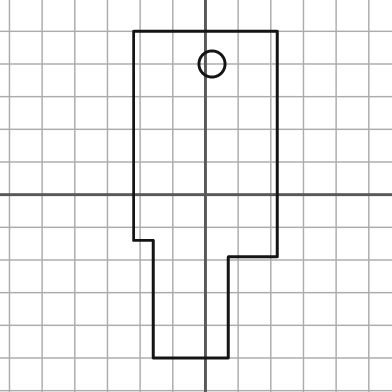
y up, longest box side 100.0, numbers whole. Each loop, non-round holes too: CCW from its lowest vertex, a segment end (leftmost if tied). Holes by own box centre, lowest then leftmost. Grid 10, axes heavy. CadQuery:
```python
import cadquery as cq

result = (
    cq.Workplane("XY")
    .moveTo(-16.0, -50.0)
    .lineTo(7.0, -50.0)
    .lineTo(7.0, -19.0)
    .lineTo(22.0, -19.0)
    .lineTo(22.0, 50.0)
    .lineTo(-22.0, 50.0)
    .lineTo(-22.0, -14.0)
    .lineTo(-16.0, -14.0)
    .close()
    .moveTo(2.0, 40.0)
    .circle(4.0)
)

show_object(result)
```